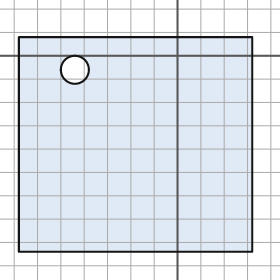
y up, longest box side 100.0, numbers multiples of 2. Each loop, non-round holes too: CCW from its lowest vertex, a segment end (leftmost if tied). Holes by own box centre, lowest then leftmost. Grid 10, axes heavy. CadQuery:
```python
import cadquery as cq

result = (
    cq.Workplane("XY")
    .moveTo(-68.0, -84.0)
    .lineTo(32.0, -84.0)
    .lineTo(32.0, 8.0)
    .lineTo(-68.0, 8.0)
    .close()
    .moveTo(-44.0, -6.0)
    .circle(6.0)
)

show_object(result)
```